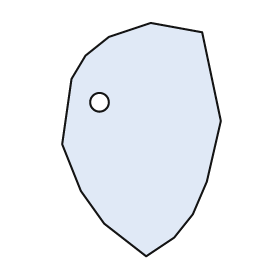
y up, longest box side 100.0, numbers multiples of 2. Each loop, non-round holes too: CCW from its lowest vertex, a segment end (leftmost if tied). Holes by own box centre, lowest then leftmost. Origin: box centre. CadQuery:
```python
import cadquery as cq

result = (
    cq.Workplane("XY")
    .moveTo(2.0, -50.0)
    .lineTo(14.0, -42.0)
    .lineTo(22.0, -32.0)
    .lineTo(28.0, -18.0)
    .lineTo(34.0, 8.0)
    .lineTo(26.0, 46.0)
    .lineTo(4.0, 50.0)
    .lineTo(-14.0, 44.0)
    .lineTo(-24.0, 36.0)
    .lineTo(-30.0, 26.0)
    .lineTo(-34.0, -2.0)
    .lineTo(-26.0, -22.0)
    .lineTo(-16.0, -36.0)
    .close()
    .moveTo(-18.0, 16.0)
    .circle(4.0)
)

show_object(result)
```